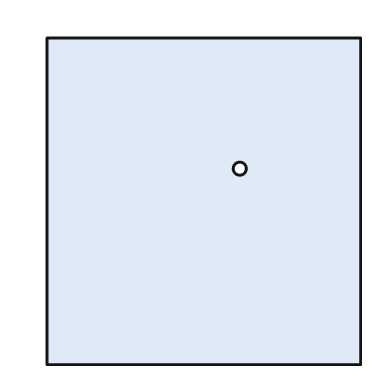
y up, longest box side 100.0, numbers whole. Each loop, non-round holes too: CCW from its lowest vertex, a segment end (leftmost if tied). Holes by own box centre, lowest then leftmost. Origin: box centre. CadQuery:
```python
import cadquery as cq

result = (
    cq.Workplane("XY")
    .moveTo(-48.0, -50.0)
    .lineTo(48.0, -50.0)
    .lineTo(48.0, 50.0)
    .lineTo(-48.0, 50.0)
    .close()
    .moveTo(11.0, 10.0)
    .circle(2.0)
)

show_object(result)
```